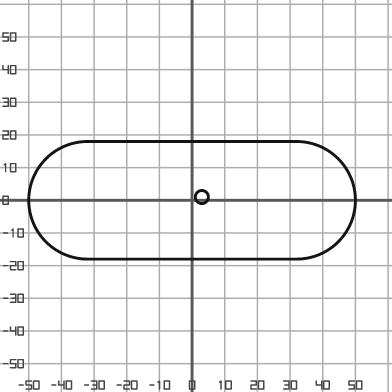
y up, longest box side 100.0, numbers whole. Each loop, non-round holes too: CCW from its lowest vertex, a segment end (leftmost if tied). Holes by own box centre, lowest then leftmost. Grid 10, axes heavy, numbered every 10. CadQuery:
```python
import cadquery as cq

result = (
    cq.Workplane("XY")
    .moveTo(-32.0, -18.0)
    .lineTo(32.0, -18.0)
    .threePointArc((50.0, 0.0), (32.0, 18.0))
    .lineTo(-32.0, 18.0)
    .threePointArc((-50.0, 0.0), (-32.0, -18.0))
    .close()
    .moveTo(3.0, 1.0)
    .circle(2.0)
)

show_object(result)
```